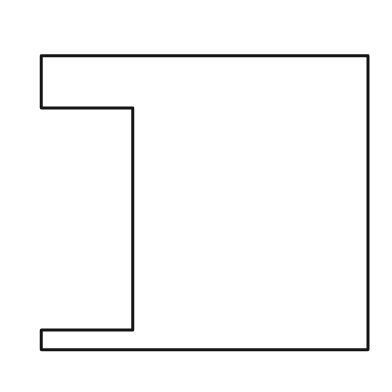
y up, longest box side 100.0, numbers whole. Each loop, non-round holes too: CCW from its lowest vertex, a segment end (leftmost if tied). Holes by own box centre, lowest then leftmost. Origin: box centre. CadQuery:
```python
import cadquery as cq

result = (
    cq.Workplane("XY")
    .moveTo(-50.0, -45.0)
    .lineTo(50.0, -45.0)
    .lineTo(50.0, 45.0)
    .lineTo(-50.0, 45.0)
    .lineTo(-50.0, 29.0)
    .lineTo(-22.0, 29.0)
    .lineTo(-22.0, -39.0)
    .lineTo(-50.0, -39.0)
    .close()
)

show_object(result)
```